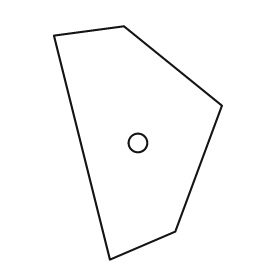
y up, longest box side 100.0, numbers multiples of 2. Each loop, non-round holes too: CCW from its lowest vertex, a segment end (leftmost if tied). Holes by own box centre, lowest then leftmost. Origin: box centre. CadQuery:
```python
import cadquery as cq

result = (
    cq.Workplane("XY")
    .moveTo(-12.0, -50.0)
    .lineTo(16.0, -38.0)
    .lineTo(36.0, 16.0)
    .lineTo(-6.0, 50.0)
    .lineTo(-36.0, 46.0)
    .close()
    .moveTo(0.0, 0.0)
    .circle(4.0)
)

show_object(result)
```